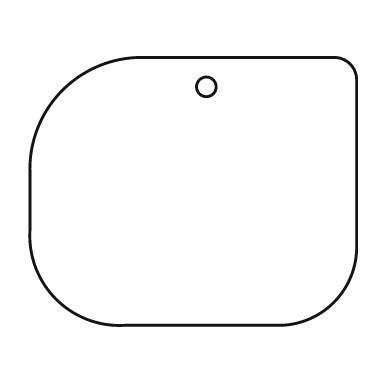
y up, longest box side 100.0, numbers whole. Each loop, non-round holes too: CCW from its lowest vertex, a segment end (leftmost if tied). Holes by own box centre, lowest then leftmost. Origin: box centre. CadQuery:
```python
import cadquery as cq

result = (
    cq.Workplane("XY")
    .moveTo(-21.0, -41.0)
    .lineTo(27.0, -41.0)
    .threePointArc((43.0, -34.0), (50.0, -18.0))
    .lineTo(50.0, 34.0)
    .threePointArc((48.0, 39.0), (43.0, 41.0))
    .lineTo(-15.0, 41.0)
    .threePointArc((-40.0, 31.0), (-50.0, 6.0))
    .lineTo(-50.0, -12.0)
    .threePointArc((-42.0, -33.0), (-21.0, -41.0))
    .close()
    .moveTo(4.0, 32.0)
    .circle(3.0)
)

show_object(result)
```